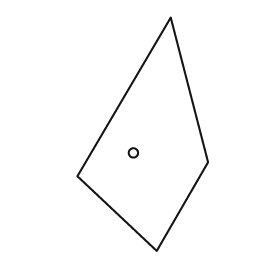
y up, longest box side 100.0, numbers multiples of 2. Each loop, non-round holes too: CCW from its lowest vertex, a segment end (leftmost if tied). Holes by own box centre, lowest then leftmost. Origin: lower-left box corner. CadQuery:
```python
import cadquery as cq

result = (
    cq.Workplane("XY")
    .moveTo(34.0, 0.0)
    .lineTo(56.0, 38.0)
    .lineTo(40.0, 100.0)
    .lineTo(0.0, 32.0)
    .close()
    .moveTo(24.0, 42.0)
    .circle(2.0)
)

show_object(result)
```